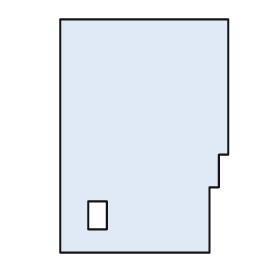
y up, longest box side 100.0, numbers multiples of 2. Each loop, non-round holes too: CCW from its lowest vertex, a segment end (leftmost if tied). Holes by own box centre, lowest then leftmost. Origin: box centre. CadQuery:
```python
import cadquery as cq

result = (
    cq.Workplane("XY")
    .moveTo(-36.0, -50.0)
    .lineTo(28.0, -50.0)
    .lineTo(28.0, -22.0)
    .lineTo(32.0, -22.0)
    .lineTo(32.0, -8.0)
    .lineTo(36.0, -8.0)
    .lineTo(36.0, 50.0)
    .lineTo(-36.0, 50.0)
    .close()
    .moveTo(-24.0, -40.0)
    .lineTo(-16.0, -40.0)
    .lineTo(-16.0, -28.0)
    .lineTo(-24.0, -28.0)
    .close()
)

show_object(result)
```